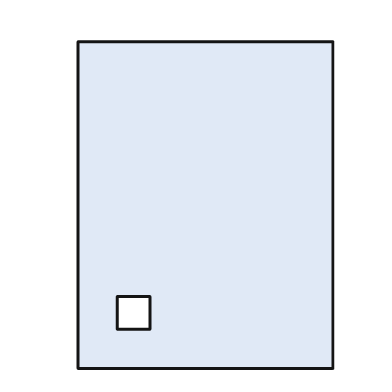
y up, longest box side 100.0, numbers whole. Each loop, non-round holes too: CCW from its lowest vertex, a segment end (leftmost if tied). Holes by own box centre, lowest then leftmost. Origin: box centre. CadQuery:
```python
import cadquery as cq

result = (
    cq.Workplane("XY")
    .moveTo(-39.0, -50.0)
    .lineTo(39.0, -50.0)
    .lineTo(39.0, 50.0)
    .lineTo(-39.0, 50.0)
    .close()
    .moveTo(-27.0, -38.0)
    .lineTo(-17.0, -38.0)
    .lineTo(-17.0, -28.0)
    .lineTo(-27.0, -28.0)
    .close()
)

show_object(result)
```